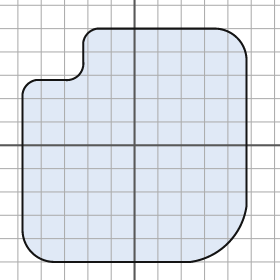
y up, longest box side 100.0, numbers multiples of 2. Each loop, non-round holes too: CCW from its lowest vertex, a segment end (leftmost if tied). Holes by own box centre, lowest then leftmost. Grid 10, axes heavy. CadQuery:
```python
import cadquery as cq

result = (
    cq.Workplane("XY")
    .moveTo(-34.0, -50.0)
    .lineTo(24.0, -50.0)
    .threePointArc((40.0, -42.0), (48.0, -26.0))
    .lineTo(48.0, 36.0)
    .threePointArc((44.0, 46.0), (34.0, 50.0))
    .lineTo(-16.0, 50.0)
    .threePointArc((-20.0, 48.0), (-22.0, 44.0))
    .lineTo(-22.0, 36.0)
    .threePointArc((-24.0, 30.0), (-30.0, 28.0))
    .lineTo(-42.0, 28.0)
    .threePointArc((-46.0, 26.0), (-48.0, 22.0))
    .lineTo(-48.0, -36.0)
    .threePointArc((-44.0, -46.0), (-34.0, -50.0))
    .close()
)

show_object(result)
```